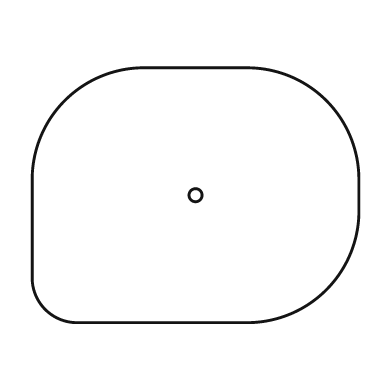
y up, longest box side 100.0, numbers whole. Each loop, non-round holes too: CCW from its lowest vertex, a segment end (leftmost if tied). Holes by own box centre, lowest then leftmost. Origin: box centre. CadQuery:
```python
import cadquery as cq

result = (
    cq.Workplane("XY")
    .moveTo(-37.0, -39.0)
    .lineTo(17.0, -39.0)
    .threePointArc((40.0, -29.0), (50.0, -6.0))
    .lineTo(50.0, 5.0)
    .threePointArc((40.0, 29.0), (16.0, 39.0))
    .lineTo(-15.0, 39.0)
    .threePointArc((-40.0, 29.0), (-50.0, 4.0))
    .lineTo(-50.0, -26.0)
    .threePointArc((-46.0, -35.0), (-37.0, -39.0))
    .close()
    .moveTo(0.0, 0.0)
    .circle(2.0)
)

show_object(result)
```